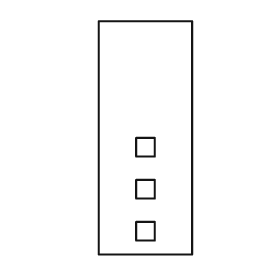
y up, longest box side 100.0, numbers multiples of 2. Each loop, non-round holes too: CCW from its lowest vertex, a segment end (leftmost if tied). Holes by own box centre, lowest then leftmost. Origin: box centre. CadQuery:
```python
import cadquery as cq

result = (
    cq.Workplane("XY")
    .moveTo(-20.0, -50.0)
    .lineTo(20.0, -50.0)
    .lineTo(20.0, 50.0)
    .lineTo(-20.0, 50.0)
    .close()
    .moveTo(-4.0, -44.0)
    .lineTo(4.0, -44.0)
    .lineTo(4.0, -36.0)
    .lineTo(-4.0, -36.0)
    .close()
    .moveTo(-4.0, -26.0)
    .lineTo(4.0, -26.0)
    .lineTo(4.0, -18.0)
    .lineTo(-4.0, -18.0)
    .close()
    .moveTo(-4.0, -8.0)
    .lineTo(4.0, -8.0)
    .lineTo(4.0, 0.0)
    .lineTo(-4.0, 0.0)
    .close()
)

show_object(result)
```